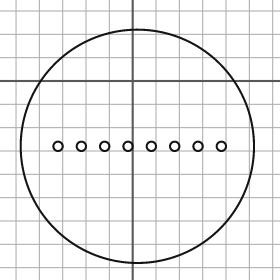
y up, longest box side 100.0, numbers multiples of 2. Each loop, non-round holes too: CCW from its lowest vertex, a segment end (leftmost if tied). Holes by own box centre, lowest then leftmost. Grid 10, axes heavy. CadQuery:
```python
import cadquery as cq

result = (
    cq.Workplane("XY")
    .moveTo(2.0, -28.0)
    .circle(50.0)
    .moveTo(-32.0, -28.0)
    .circle(2.0)
    .moveTo(-22.0, -28.0)
    .circle(2.0)
    .moveTo(-12.0, -28.0)
    .circle(2.0)
    .moveTo(-2.0, -28.0)
    .circle(2.0)
    .moveTo(8.0, -28.0)
    .circle(2.0)
    .moveTo(18.0, -28.0)
    .circle(2.0)
    .moveTo(28.0, -28.0)
    .circle(2.0)
    .moveTo(38.0, -28.0)
    .circle(2.0)
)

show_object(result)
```